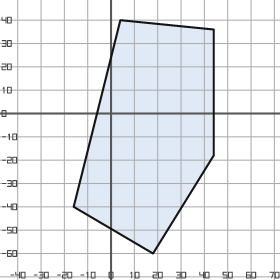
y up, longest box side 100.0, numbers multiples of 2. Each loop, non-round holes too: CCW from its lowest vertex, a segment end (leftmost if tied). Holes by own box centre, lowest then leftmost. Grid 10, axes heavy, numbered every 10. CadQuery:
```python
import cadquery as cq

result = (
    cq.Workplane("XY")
    .moveTo(18.0, -60.0)
    .lineTo(44.0, -18.0)
    .lineTo(44.0, 36.0)
    .lineTo(4.0, 40.0)
    .lineTo(-16.0, -40.0)
    .close()
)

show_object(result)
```